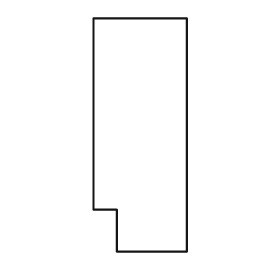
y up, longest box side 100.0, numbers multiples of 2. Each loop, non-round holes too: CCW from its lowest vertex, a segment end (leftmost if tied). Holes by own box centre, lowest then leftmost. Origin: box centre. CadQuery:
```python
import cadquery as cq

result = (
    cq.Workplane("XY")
    .moveTo(-10.0, -50.0)
    .lineTo(20.0, -50.0)
    .lineTo(20.0, 50.0)
    .lineTo(-20.0, 50.0)
    .lineTo(-20.0, -32.0)
    .lineTo(-10.0, -32.0)
    .close()
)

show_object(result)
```